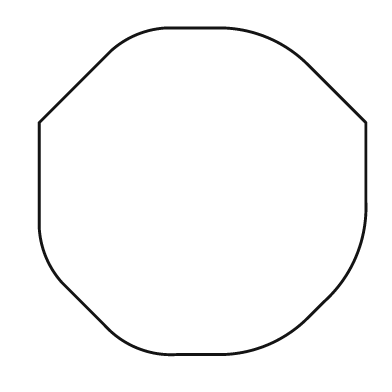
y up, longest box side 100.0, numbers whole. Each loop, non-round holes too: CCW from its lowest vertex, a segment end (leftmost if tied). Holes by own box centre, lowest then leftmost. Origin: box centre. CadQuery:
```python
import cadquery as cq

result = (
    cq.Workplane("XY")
    .moveTo(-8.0, -50.0)
    .lineTo(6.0, -50.0)
    .threePointArc((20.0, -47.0), (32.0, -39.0))
    .lineTo(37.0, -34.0)
    .threePointArc((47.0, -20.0), (50.0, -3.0))
    .lineTo(50.0, 21.0)
    .lineTo(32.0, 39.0)
    .threePointArc((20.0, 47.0), (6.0, 50.0))
    .lineTo(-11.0, 50.0)
    .threePointArc((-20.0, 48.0), (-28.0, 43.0))
    .lineTo(-50.0, 21.0)
    .lineTo(-50.0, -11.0)
    .threePointArc((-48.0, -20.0), (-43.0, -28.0))
    .lineTo(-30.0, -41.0)
    .threePointArc((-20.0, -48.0), (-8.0, -50.0))
    .close()
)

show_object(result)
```